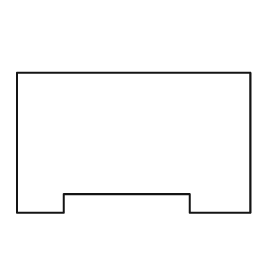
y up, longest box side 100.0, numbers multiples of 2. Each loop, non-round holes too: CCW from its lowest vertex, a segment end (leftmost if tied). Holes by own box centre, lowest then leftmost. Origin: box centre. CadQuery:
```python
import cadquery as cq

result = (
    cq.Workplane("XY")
    .moveTo(-50.0, -30.0)
    .lineTo(-30.0, -30.0)
    .lineTo(-30.0, -22.0)
    .lineTo(24.0, -22.0)
    .lineTo(24.0, -30.0)
    .lineTo(50.0, -30.0)
    .lineTo(50.0, 30.0)
    .lineTo(-50.0, 30.0)
    .close()
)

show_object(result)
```